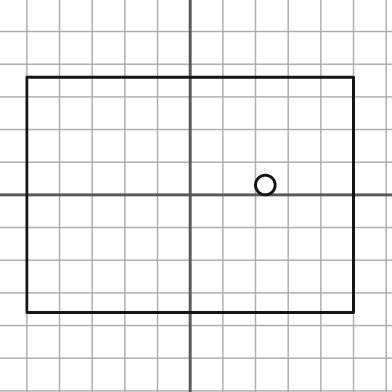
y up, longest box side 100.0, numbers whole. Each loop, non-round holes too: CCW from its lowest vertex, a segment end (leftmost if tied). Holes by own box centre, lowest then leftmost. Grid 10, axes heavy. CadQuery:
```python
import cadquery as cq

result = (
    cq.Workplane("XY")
    .moveTo(-50.0, -36.0)
    .lineTo(50.0, -36.0)
    .lineTo(50.0, 36.0)
    .lineTo(-50.0, 36.0)
    .close()
    .moveTo(23.0, 3.0)
    .circle(3.0)
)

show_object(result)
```